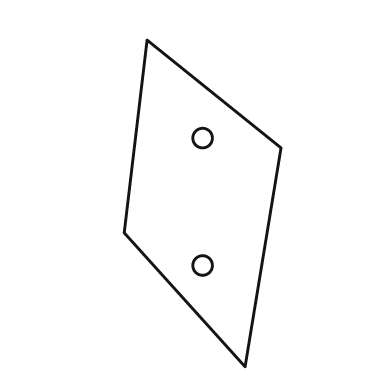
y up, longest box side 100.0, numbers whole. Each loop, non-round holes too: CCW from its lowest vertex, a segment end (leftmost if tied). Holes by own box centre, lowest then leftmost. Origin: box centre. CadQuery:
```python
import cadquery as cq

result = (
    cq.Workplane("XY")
    .moveTo(13.0, -50.0)
    .lineTo(24.0, 17.0)
    .lineTo(-17.0, 50.0)
    .lineTo(-24.0, -9.0)
    .close()
    .moveTo(0.0, -19.0)
    .circle(3.0)
    .moveTo(0.0, 20.0)
    .circle(3.0)
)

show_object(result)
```